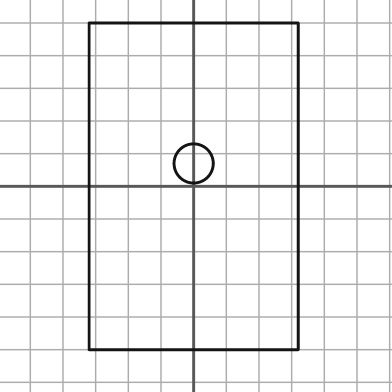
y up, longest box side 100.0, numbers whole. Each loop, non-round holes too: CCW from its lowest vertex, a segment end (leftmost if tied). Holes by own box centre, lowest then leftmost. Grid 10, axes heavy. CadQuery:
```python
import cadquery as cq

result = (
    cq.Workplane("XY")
    .moveTo(-32.0, -50.0)
    .lineTo(32.0, -50.0)
    .lineTo(32.0, 50.0)
    .lineTo(-32.0, 50.0)
    .close()
    .moveTo(0.0, 7.0)
    .circle(6.0)
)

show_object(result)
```